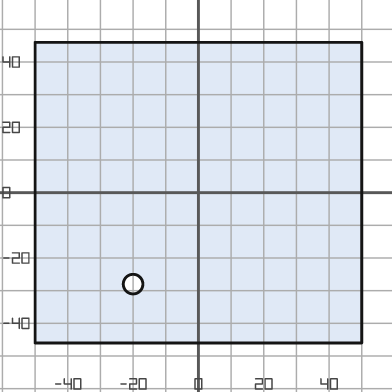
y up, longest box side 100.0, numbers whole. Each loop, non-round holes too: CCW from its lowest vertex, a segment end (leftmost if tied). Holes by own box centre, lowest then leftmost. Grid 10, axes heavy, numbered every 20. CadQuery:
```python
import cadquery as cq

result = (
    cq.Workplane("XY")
    .moveTo(-50.0, -46.0)
    .lineTo(50.0, -46.0)
    .lineTo(50.0, 46.0)
    .lineTo(-50.0, 46.0)
    .close()
    .moveTo(-20.0, -28.0)
    .circle(3.0)
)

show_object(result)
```